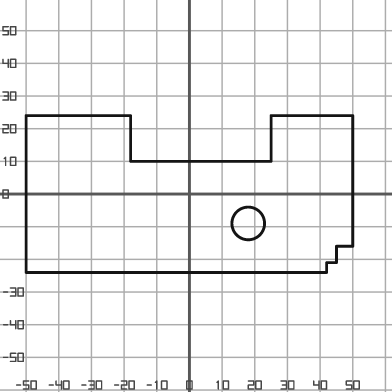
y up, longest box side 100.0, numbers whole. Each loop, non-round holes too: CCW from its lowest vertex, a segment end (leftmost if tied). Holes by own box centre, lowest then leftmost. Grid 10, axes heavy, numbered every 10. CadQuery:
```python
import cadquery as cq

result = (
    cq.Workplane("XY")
    .moveTo(-50.0, -24.0)
    .lineTo(42.0, -24.0)
    .lineTo(42.0, -21.0)
    .lineTo(45.0, -21.0)
    .lineTo(45.0, -16.0)
    .lineTo(50.0, -16.0)
    .lineTo(50.0, 24.0)
    .lineTo(25.0, 24.0)
    .lineTo(25.0, 10.0)
    .lineTo(-18.0, 10.0)
    .lineTo(-18.0, 24.0)
    .lineTo(-50.0, 24.0)
    .close()
    .moveTo(18.0, -9.0)
    .circle(5.0)
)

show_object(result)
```